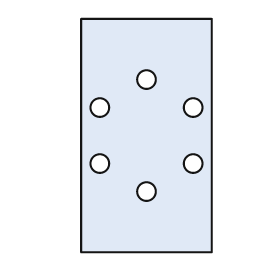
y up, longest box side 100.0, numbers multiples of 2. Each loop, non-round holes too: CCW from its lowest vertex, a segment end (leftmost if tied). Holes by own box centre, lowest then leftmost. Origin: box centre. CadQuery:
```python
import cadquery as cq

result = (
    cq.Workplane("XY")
    .moveTo(-28.0, -50.0)
    .lineTo(28.0, -50.0)
    .lineTo(28.0, 50.0)
    .lineTo(-28.0, 50.0)
    .close()
    .moveTo(0.0, -24.0)
    .circle(4.0)
    .moveTo(-20.0, -12.0)
    .circle(4.0)
    .moveTo(20.0, -12.0)
    .circle(4.0)
    .moveTo(-20.0, 12.0)
    .circle(4.0)
    .moveTo(20.0, 12.0)
    .circle(4.0)
    .moveTo(0.0, 24.0)
    .circle(4.0)
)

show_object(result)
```